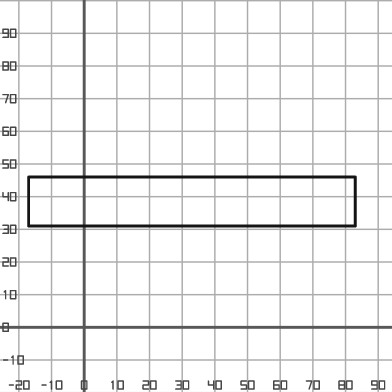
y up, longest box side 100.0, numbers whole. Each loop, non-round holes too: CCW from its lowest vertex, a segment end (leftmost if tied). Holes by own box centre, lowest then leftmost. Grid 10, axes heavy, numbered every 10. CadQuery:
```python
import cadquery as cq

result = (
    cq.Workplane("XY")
    .moveTo(-17.0, 31.0)
    .lineTo(83.0, 31.0)
    .lineTo(83.0, 46.0)
    .lineTo(-17.0, 46.0)
    .close()
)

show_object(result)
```